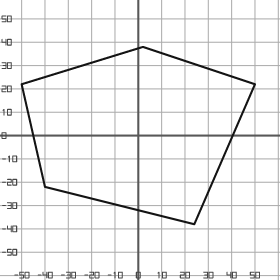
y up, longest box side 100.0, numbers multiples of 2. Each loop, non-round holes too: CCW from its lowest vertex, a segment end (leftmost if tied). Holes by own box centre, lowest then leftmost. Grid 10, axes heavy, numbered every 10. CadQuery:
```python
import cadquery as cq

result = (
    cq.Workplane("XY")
    .moveTo(24.0, -38.0)
    .lineTo(50.0, 22.0)
    .lineTo(2.0, 38.0)
    .lineTo(-50.0, 22.0)
    .lineTo(-40.0, -22.0)
    .close()
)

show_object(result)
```